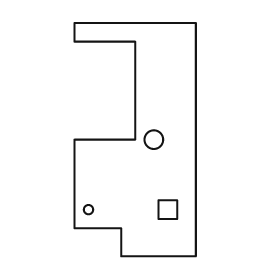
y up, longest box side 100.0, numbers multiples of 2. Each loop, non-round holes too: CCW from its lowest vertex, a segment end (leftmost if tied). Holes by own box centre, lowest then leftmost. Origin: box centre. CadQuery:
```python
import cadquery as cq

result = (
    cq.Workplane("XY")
    .moveTo(-6.0, -50.0)
    .lineTo(26.0, -50.0)
    .lineTo(26.0, 50.0)
    .lineTo(-26.0, 50.0)
    .lineTo(-26.0, 42.0)
    .lineTo(0.0, 42.0)
    .lineTo(0.0, 0.0)
    .lineTo(-26.0, 0.0)
    .lineTo(-26.0, -38.0)
    .lineTo(-6.0, -38.0)
    .close()
    .moveTo(-20.0, -30.0)
    .circle(2.0)
    .moveTo(10.0, -34.0)
    .lineTo(18.0, -34.0)
    .lineTo(18.0, -26.0)
    .lineTo(10.0, -26.0)
    .close()
    .moveTo(8.0, 0.0)
    .circle(4.0)
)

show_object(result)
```